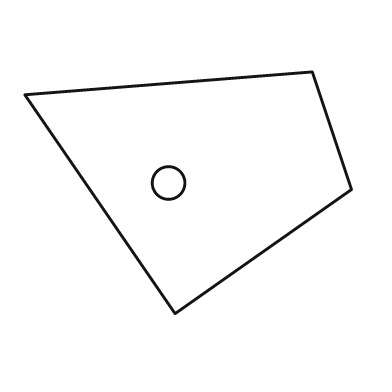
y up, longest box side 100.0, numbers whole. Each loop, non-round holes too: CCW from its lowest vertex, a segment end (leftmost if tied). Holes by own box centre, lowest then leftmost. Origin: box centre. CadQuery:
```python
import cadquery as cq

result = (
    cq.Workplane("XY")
    .moveTo(-4.0, -37.0)
    .lineTo(50.0, 1.0)
    .lineTo(38.0, 37.0)
    .lineTo(-50.0, 30.0)
    .close()
    .moveTo(-6.0, 3.0)
    .circle(5.0)
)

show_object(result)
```